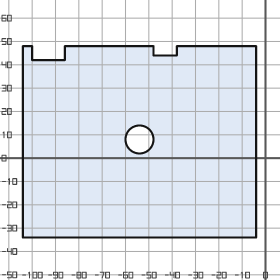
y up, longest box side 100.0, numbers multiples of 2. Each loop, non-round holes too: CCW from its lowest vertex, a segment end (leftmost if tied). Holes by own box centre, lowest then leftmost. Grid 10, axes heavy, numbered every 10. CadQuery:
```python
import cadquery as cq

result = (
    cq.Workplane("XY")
    .moveTo(-104.0, -34.0)
    .lineTo(-4.0, -34.0)
    .lineTo(-4.0, 48.0)
    .lineTo(-38.0, 48.0)
    .lineTo(-38.0, 44.0)
    .lineTo(-48.0, 44.0)
    .lineTo(-48.0, 48.0)
    .lineTo(-86.0, 48.0)
    .lineTo(-86.0, 42.0)
    .lineTo(-100.0, 42.0)
    .lineTo(-100.0, 48.0)
    .lineTo(-104.0, 48.0)
    .close()
    .moveTo(-54.0, 8.0)
    .circle(6.0)
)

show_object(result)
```